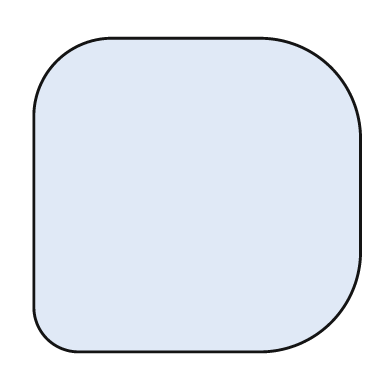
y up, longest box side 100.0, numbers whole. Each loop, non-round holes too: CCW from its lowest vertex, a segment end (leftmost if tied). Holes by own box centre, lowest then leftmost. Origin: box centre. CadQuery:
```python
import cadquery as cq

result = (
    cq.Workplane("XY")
    .moveTo(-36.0, -48.0)
    .lineTo(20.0, -48.0)
    .threePointArc((41.0, -39.0), (50.0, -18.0))
    .lineTo(50.0, 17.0)
    .threePointArc((41.0, 39.0), (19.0, 48.0))
    .lineTo(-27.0, 48.0)
    .threePointArc((-43.0, 41.0), (-50.0, 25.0))
    .lineTo(-50.0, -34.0)
    .threePointArc((-46.0, -44.0), (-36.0, -48.0))
    .close()
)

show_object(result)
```